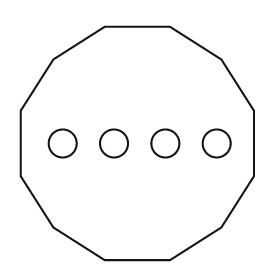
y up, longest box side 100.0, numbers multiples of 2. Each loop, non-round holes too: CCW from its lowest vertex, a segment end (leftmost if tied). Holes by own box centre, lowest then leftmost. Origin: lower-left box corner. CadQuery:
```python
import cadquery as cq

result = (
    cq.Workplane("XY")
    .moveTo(36.0, 0.0)
    .lineTo(64.0, 0.0)
    .lineTo(86.0, 14.0)
    .lineTo(100.0, 36.0)
    .lineTo(100.0, 64.0)
    .lineTo(86.0, 86.0)
    .lineTo(64.0, 100.0)
    .lineTo(36.0, 100.0)
    .lineTo(14.0, 86.0)
    .lineTo(0.0, 64.0)
    .lineTo(0.0, 36.0)
    .lineTo(14.0, 14.0)
    .close()
    .moveTo(18.0, 50.0)
    .circle(6.0)
    .moveTo(40.0, 50.0)
    .circle(6.0)
    .moveTo(62.0, 50.0)
    .circle(6.0)
    .moveTo(84.0, 50.0)
    .circle(6.0)
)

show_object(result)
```